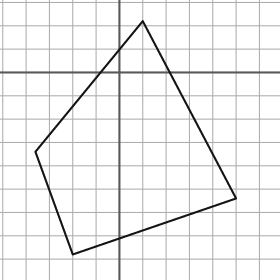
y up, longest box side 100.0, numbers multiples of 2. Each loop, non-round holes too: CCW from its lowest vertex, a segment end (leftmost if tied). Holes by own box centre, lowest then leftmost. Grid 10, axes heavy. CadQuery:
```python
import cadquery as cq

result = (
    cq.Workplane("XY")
    .moveTo(-20.0, -78.0)
    .lineTo(50.0, -54.0)
    .lineTo(10.0, 22.0)
    .lineTo(-36.0, -34.0)
    .close()
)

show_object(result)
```